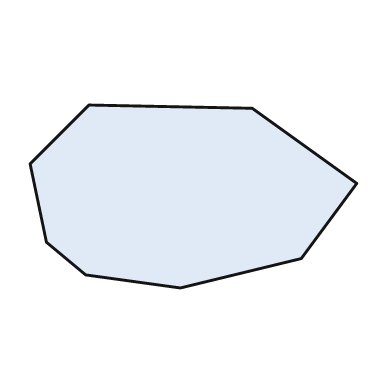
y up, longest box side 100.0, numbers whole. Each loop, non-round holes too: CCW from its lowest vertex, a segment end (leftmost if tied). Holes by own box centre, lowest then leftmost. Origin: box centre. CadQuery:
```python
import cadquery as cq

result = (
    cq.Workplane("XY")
    .moveTo(-4.0, -28.0)
    .lineTo(33.0, -19.0)
    .lineTo(50.0, 4.0)
    .lineTo(18.0, 27.0)
    .lineTo(-32.0, 28.0)
    .lineTo(-50.0, 10.0)
    .lineTo(-45.0, -14.0)
    .lineTo(-33.0, -24.0)
    .close()
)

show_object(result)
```